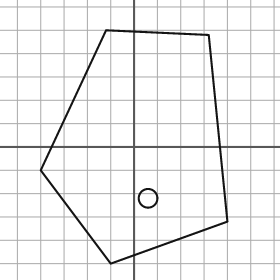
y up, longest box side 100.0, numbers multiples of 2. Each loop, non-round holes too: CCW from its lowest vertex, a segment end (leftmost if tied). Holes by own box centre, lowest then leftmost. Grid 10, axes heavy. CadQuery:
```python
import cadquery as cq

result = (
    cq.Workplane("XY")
    .moveTo(-10.0, -50.0)
    .lineTo(40.0, -32.0)
    .lineTo(32.0, 48.0)
    .lineTo(-12.0, 50.0)
    .lineTo(-40.0, -10.0)
    .close()
    .moveTo(6.0, -22.0)
    .circle(4.0)
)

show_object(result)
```